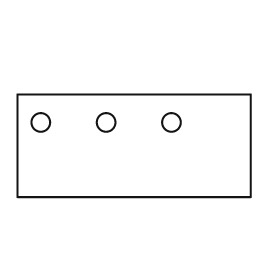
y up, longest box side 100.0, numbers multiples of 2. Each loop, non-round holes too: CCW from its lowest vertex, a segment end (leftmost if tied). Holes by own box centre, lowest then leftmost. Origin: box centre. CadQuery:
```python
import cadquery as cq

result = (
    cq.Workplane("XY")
    .moveTo(-50.0, -22.0)
    .lineTo(50.0, -22.0)
    .lineTo(50.0, 22.0)
    .lineTo(-50.0, 22.0)
    .close()
    .moveTo(-40.0, 10.0)
    .circle(4.0)
    .moveTo(-12.0, 10.0)
    .circle(4.0)
    .moveTo(16.0, 10.0)
    .circle(4.0)
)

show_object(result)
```